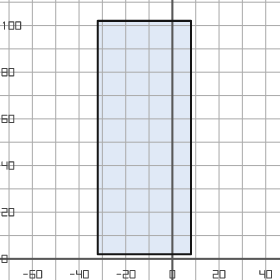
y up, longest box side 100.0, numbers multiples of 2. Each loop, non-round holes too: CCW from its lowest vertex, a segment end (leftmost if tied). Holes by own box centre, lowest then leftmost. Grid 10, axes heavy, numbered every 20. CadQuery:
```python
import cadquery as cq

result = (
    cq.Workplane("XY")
    .moveTo(-32.0, 2.0)
    .lineTo(8.0, 2.0)
    .lineTo(8.0, 102.0)
    .lineTo(-32.0, 102.0)
    .close()
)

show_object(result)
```